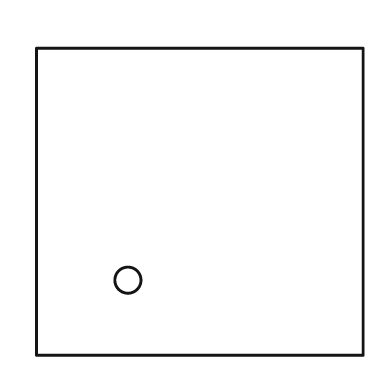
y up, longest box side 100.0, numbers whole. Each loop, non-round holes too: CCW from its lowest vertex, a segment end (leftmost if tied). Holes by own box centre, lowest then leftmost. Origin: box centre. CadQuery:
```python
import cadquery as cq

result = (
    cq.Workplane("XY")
    .moveTo(-50.0, -47.0)
    .lineTo(50.0, -47.0)
    .lineTo(50.0, 47.0)
    .lineTo(-50.0, 47.0)
    .close()
    .moveTo(-22.0, -24.0)
    .circle(4.0)
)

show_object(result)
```